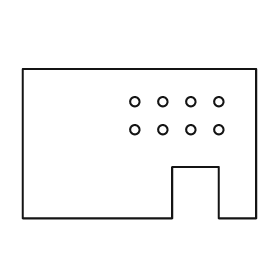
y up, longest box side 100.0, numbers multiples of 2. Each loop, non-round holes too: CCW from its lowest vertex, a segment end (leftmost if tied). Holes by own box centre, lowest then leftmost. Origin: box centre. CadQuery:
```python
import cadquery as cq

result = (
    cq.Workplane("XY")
    .moveTo(-50.0, -32.0)
    .lineTo(14.0, -32.0)
    .lineTo(14.0, -10.0)
    .lineTo(34.0, -10.0)
    .lineTo(34.0, -32.0)
    .lineTo(50.0, -32.0)
    .lineTo(50.0, 32.0)
    .lineTo(-50.0, 32.0)
    .close()
    .moveTo(-2.0, 6.0)
    .circle(2.0)
    .moveTo(10.0, 6.0)
    .circle(2.0)
    .moveTo(22.0, 6.0)
    .circle(2.0)
    .moveTo(34.0, 6.0)
    .circle(2.0)
    .moveTo(-2.0, 18.0)
    .circle(2.0)
    .moveTo(10.0, 18.0)
    .circle(2.0)
    .moveTo(22.0, 18.0)
    .circle(2.0)
    .moveTo(34.0, 18.0)
    .circle(2.0)
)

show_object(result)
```